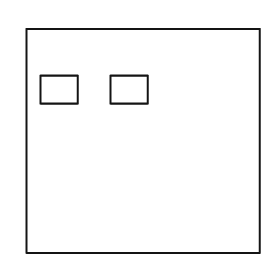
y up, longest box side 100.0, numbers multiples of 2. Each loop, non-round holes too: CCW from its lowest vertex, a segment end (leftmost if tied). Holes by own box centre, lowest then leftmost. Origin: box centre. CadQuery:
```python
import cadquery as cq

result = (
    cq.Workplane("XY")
    .moveTo(-50.0, -48.0)
    .lineTo(50.0, -48.0)
    .lineTo(50.0, 48.0)
    .lineTo(-50.0, 48.0)
    .close()
    .moveTo(-44.0, 16.0)
    .lineTo(-28.0, 16.0)
    .lineTo(-28.0, 28.0)
    .lineTo(-44.0, 28.0)
    .close()
    .moveTo(-14.0, 16.0)
    .lineTo(2.0, 16.0)
    .lineTo(2.0, 28.0)
    .lineTo(-14.0, 28.0)
    .close()
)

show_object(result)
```